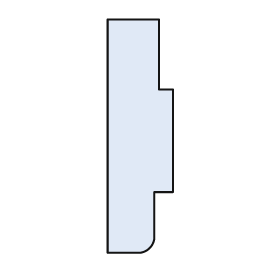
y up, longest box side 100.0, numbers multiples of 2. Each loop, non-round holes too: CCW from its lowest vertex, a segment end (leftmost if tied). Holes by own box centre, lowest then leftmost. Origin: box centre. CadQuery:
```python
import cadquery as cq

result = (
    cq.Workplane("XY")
    .moveTo(-14.0, -50.0)
    .lineTo(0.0, -50.0)
    .threePointArc((4.0, -48.0), (6.0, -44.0))
    .lineTo(6.0, -24.0)
    .lineTo(14.0, -24.0)
    .lineTo(14.0, 20.0)
    .lineTo(8.0, 20.0)
    .lineTo(8.0, 50.0)
    .lineTo(-14.0, 50.0)
    .close()
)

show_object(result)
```